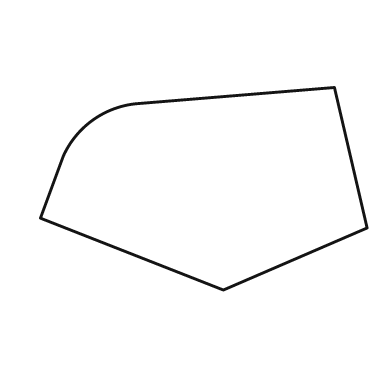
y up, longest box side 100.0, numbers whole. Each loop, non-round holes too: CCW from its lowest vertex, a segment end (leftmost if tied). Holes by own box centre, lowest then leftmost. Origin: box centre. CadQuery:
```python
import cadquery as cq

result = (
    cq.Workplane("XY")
    .moveTo(6.0, -31.0)
    .lineTo(50.0, -12.0)
    .lineTo(40.0, 31.0)
    .lineTo(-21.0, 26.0)
    .threePointArc((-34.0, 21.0), (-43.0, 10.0))
    .lineTo(-50.0, -9.0)
    .close()
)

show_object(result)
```